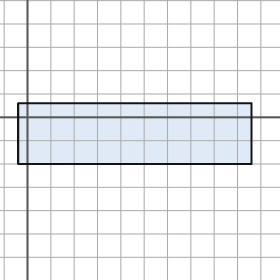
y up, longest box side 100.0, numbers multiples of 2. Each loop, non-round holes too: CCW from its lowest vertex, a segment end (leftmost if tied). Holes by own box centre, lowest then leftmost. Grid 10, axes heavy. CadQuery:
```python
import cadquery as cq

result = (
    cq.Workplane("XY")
    .moveTo(-4.0, -20.0)
    .lineTo(96.0, -20.0)
    .lineTo(96.0, 6.0)
    .lineTo(-4.0, 6.0)
    .close()
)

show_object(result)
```